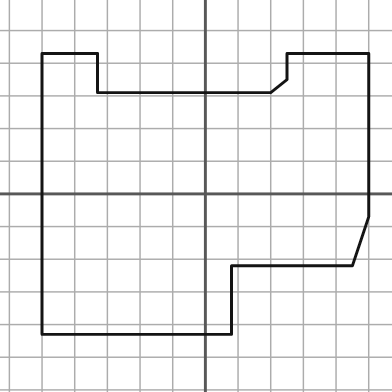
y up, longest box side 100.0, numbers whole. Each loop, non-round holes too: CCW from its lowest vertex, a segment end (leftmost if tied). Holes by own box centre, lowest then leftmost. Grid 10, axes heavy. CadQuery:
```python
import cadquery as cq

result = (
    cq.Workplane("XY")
    .moveTo(-50.0, -43.0)
    .lineTo(8.0, -43.0)
    .lineTo(8.0, -22.0)
    .lineTo(45.0, -22.0)
    .lineTo(50.0, -7.0)
    .lineTo(50.0, 43.0)
    .lineTo(25.0, 43.0)
    .lineTo(25.0, 35.0)
    .lineTo(20.0, 31.0)
    .lineTo(-33.0, 31.0)
    .lineTo(-33.0, 43.0)
    .lineTo(-50.0, 43.0)
    .close()
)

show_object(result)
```